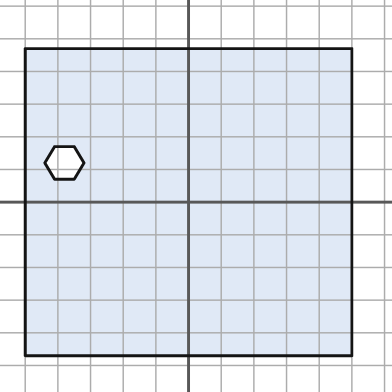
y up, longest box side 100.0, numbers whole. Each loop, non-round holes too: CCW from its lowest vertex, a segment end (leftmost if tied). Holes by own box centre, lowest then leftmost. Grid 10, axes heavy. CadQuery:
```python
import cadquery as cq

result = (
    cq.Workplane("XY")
    .moveTo(-50.0, -47.0)
    .lineTo(50.0, -47.0)
    .lineTo(50.0, 47.0)
    .lineTo(-50.0, 47.0)
    .close()
    .moveTo(-41.0, 7.0)
    .lineTo(-35.0, 7.0)
    .lineTo(-32.0, 12.0)
    .lineTo(-35.0, 17.0)
    .lineTo(-41.0, 17.0)
    .lineTo(-44.0, 12.0)
    .close()
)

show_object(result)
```